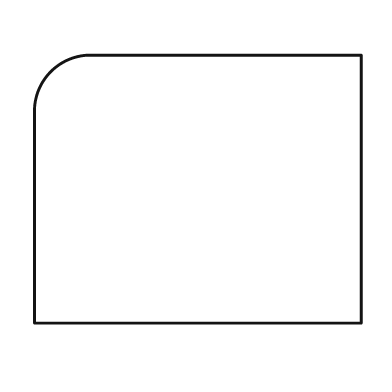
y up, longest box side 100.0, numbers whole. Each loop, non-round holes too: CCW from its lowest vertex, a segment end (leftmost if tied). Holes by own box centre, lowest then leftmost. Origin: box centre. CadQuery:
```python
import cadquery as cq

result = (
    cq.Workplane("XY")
    .moveTo(-50.0, -41.0)
    .lineTo(50.0, -41.0)
    .lineTo(50.0, 41.0)
    .lineTo(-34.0, 41.0)
    .threePointArc((-45.0, 36.0), (-50.0, 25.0))
    .close()
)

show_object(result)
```